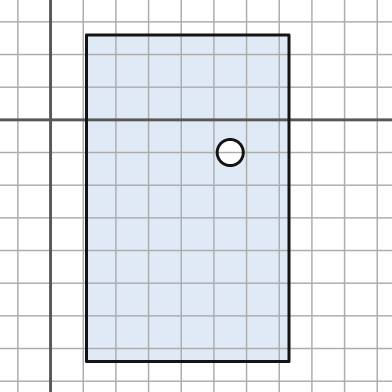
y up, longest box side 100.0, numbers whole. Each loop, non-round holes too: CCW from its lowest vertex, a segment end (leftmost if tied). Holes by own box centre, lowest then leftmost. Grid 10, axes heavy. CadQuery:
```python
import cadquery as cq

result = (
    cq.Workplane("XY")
    .moveTo(11.0, -74.0)
    .lineTo(73.0, -74.0)
    .lineTo(73.0, 26.0)
    .lineTo(11.0, 26.0)
    .close()
    .moveTo(55.0, -10.0)
    .circle(4.0)
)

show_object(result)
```